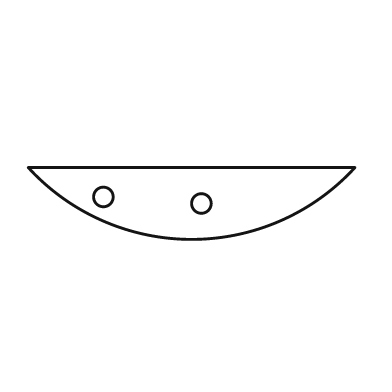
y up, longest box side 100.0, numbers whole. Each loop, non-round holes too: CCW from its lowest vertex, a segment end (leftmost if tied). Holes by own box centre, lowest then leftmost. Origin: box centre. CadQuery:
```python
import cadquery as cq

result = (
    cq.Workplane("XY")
    .moveTo(-50.0, 11.0)
    .threePointArc((0.0, -11.0), (50.0, 11.0))
    .close()
    .moveTo(3.0, 0.0)
    .circle(3.0)
    .moveTo(-27.0, 2.0)
    .circle(3.0)
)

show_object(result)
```